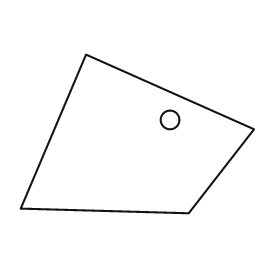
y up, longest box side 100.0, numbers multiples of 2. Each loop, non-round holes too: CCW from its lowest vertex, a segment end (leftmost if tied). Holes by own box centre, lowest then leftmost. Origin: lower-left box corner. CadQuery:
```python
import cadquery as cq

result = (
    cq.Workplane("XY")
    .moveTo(72.0, 0.0)
    .lineTo(100.0, 36.0)
    .lineTo(28.0, 68.0)
    .lineTo(0.0, 2.0)
    .close()
    .moveTo(64.0, 40.0)
    .circle(4.0)
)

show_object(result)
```